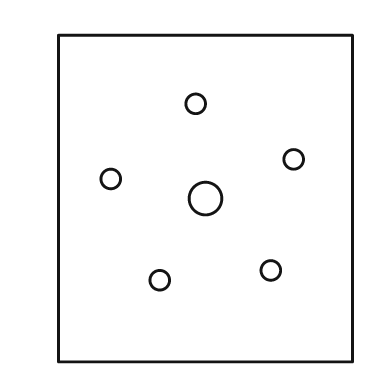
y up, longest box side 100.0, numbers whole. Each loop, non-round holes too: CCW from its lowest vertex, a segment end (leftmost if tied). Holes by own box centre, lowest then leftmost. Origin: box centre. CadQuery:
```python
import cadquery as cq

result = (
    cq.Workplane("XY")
    .moveTo(-45.0, -50.0)
    .lineTo(45.0, -50.0)
    .lineTo(45.0, 50.0)
    .lineTo(-45.0, 50.0)
    .close()
    .moveTo(-14.0, -25.0)
    .circle(3.0)
    .moveTo(20.0, -22.0)
    .circle(3.0)
    .moveTo(0.0, 0.0)
    .circle(5.0)
    .moveTo(-29.0, 6.0)
    .circle(3.0)
    .moveTo(27.0, 12.0)
    .circle(3.0)
    .moveTo(-3.0, 29.0)
    .circle(3.0)
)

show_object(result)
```